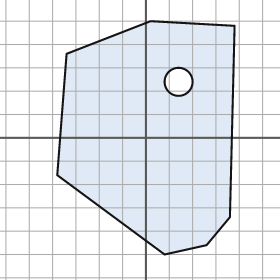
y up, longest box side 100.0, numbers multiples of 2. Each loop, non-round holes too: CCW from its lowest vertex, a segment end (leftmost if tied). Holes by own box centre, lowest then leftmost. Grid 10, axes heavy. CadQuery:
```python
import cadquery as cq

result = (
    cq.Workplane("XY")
    .moveTo(8.0, -50.0)
    .lineTo(26.0, -46.0)
    .lineTo(36.0, -34.0)
    .lineTo(38.0, 48.0)
    .lineTo(2.0, 50.0)
    .lineTo(-34.0, 36.0)
    .lineTo(-38.0, -16.0)
    .close()
    .moveTo(14.0, 24.0)
    .circle(6.0)
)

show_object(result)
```